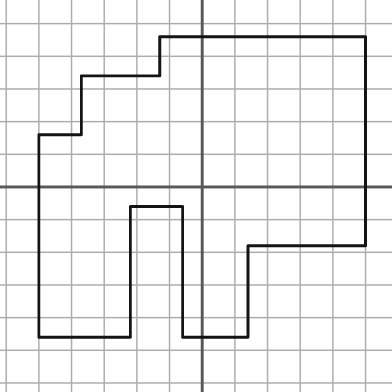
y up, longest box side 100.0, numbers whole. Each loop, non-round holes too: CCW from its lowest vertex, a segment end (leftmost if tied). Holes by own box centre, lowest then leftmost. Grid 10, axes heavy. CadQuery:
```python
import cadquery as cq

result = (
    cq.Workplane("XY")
    .moveTo(-50.0, -46.0)
    .lineTo(-22.0, -46.0)
    .lineTo(-22.0, -6.0)
    .lineTo(-6.0, -6.0)
    .lineTo(-6.0, -46.0)
    .lineTo(14.0, -46.0)
    .lineTo(14.0, -18.0)
    .lineTo(50.0, -18.0)
    .lineTo(50.0, 46.0)
    .lineTo(-13.0, 46.0)
    .lineTo(-13.0, 34.0)
    .lineTo(-37.0, 34.0)
    .lineTo(-37.0, 16.0)
    .lineTo(-50.0, 16.0)
    .close()
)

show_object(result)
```